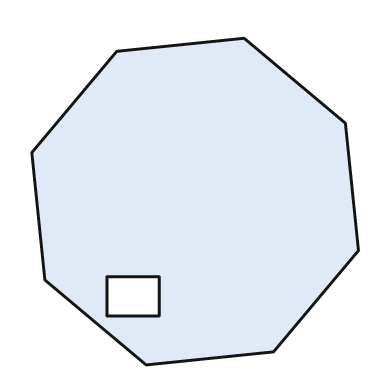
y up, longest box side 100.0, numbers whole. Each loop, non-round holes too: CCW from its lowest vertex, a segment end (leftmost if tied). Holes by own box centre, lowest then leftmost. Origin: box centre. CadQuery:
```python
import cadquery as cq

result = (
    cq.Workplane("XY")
    .moveTo(-15.0, -50.0)
    .lineTo(24.0, -46.0)
    .lineTo(50.0, -15.0)
    .lineTo(46.0, 24.0)
    .lineTo(15.0, 50.0)
    .lineTo(-24.0, 46.0)
    .lineTo(-50.0, 15.0)
    .lineTo(-46.0, -24.0)
    .close()
    .moveTo(-27.0, -35.0)
    .lineTo(-11.0, -35.0)
    .lineTo(-11.0, -23.0)
    .lineTo(-27.0, -23.0)
    .close()
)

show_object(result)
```